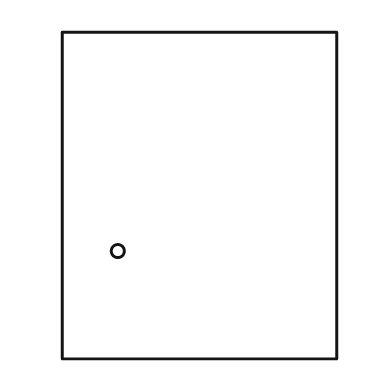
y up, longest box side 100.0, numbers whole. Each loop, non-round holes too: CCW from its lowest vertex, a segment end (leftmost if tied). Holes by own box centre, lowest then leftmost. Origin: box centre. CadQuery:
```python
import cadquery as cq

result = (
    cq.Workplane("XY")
    .moveTo(-42.0, -50.0)
    .lineTo(42.0, -50.0)
    .lineTo(42.0, 50.0)
    .lineTo(-42.0, 50.0)
    .close()
    .moveTo(-25.0, -17.0)
    .circle(2.0)
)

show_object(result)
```